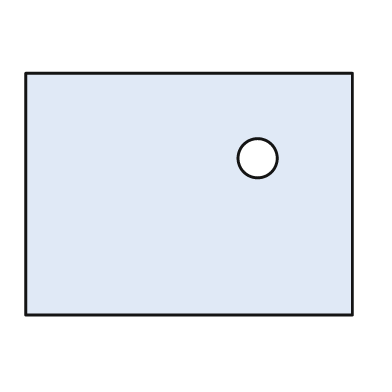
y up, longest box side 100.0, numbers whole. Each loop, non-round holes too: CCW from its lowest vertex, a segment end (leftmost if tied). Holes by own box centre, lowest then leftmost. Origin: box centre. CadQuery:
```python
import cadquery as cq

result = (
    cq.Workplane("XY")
    .moveTo(-50.0, -37.0)
    .lineTo(50.0, -37.0)
    .lineTo(50.0, 37.0)
    .lineTo(-50.0, 37.0)
    .close()
    .moveTo(21.0, 11.0)
    .circle(6.0)
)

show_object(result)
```